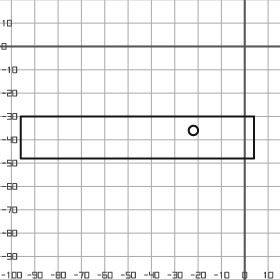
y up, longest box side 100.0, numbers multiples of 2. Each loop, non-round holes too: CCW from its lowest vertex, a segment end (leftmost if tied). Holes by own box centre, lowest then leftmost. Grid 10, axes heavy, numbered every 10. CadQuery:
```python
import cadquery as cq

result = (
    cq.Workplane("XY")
    .moveTo(-96.0, -48.0)
    .lineTo(4.0, -48.0)
    .lineTo(4.0, -30.0)
    .lineTo(-96.0, -30.0)
    .close()
    .moveTo(-22.0, -36.0)
    .circle(2.0)
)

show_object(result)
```